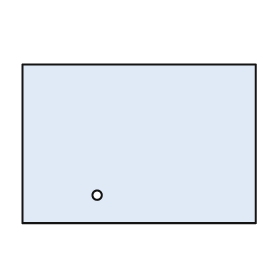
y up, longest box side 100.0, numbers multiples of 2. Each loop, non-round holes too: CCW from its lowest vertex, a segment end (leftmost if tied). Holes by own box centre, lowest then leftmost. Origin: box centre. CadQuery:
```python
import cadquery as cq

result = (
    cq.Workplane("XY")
    .moveTo(-50.0, -34.0)
    .lineTo(50.0, -34.0)
    .lineTo(50.0, 34.0)
    .lineTo(-50.0, 34.0)
    .close()
    .moveTo(-18.0, -22.0)
    .circle(2.0)
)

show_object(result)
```